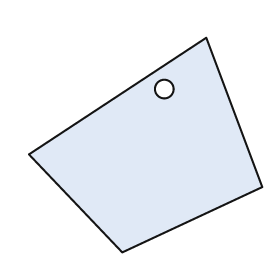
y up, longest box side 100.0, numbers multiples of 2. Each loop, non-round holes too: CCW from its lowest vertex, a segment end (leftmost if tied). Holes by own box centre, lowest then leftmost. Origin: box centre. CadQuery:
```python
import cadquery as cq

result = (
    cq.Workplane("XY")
    .moveTo(-10.0, -46.0)
    .lineTo(50.0, -18.0)
    .lineTo(26.0, 46.0)
    .lineTo(-50.0, -4.0)
    .close()
    .moveTo(8.0, 24.0)
    .circle(4.0)
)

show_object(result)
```